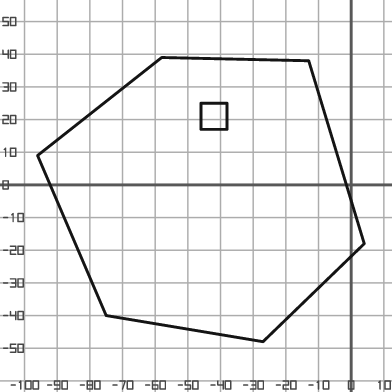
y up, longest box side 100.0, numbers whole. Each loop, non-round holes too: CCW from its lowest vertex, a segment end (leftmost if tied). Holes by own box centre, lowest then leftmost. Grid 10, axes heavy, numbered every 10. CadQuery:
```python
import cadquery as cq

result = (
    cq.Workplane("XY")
    .moveTo(-27.0, -48.0)
    .lineTo(4.0, -18.0)
    .lineTo(-13.0, 38.0)
    .lineTo(-58.0, 39.0)
    .lineTo(-96.0, 9.0)
    .lineTo(-75.0, -40.0)
    .close()
    .moveTo(-46.0, 17.0)
    .lineTo(-38.0, 17.0)
    .lineTo(-38.0, 25.0)
    .lineTo(-46.0, 25.0)
    .close()
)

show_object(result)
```